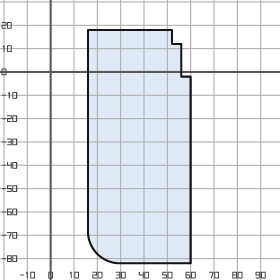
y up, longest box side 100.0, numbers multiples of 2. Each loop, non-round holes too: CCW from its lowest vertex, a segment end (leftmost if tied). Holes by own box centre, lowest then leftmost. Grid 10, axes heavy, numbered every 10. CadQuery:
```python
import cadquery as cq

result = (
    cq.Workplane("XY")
    .moveTo(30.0, -82.0)
    .lineTo(60.0, -82.0)
    .lineTo(60.0, -2.0)
    .lineTo(56.0, -2.0)
    .lineTo(56.0, 12.0)
    .lineTo(52.0, 12.0)
    .lineTo(52.0, 18.0)
    .lineTo(16.0, 18.0)
    .lineTo(16.0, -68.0)
    .threePointArc((20.0, -78.0), (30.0, -82.0))
    .close()
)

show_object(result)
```